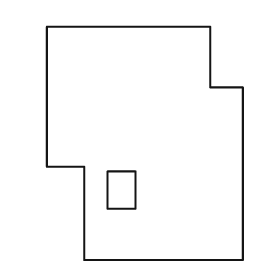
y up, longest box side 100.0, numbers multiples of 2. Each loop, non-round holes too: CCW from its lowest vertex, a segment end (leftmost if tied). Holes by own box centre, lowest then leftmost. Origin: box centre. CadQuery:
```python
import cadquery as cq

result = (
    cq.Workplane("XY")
    .moveTo(-26.0, -50.0)
    .lineTo(42.0, -50.0)
    .lineTo(42.0, 24.0)
    .lineTo(28.0, 24.0)
    .lineTo(28.0, 50.0)
    .lineTo(-42.0, 50.0)
    .lineTo(-42.0, -10.0)
    .lineTo(-26.0, -10.0)
    .close()
    .moveTo(-16.0, -28.0)
    .lineTo(-4.0, -28.0)
    .lineTo(-4.0, -12.0)
    .lineTo(-16.0, -12.0)
    .close()
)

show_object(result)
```